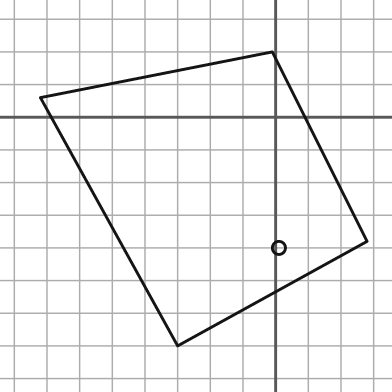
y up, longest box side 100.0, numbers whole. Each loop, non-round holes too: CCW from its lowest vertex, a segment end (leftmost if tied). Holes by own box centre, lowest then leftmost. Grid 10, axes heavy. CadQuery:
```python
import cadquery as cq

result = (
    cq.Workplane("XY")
    .moveTo(-30.0, -70.0)
    .lineTo(28.0, -38.0)
    .lineTo(-1.0, 20.0)
    .lineTo(-72.0, 6.0)
    .close()
    .moveTo(1.0, -40.0)
    .circle(2.0)
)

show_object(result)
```